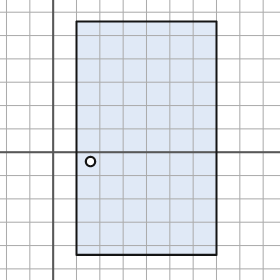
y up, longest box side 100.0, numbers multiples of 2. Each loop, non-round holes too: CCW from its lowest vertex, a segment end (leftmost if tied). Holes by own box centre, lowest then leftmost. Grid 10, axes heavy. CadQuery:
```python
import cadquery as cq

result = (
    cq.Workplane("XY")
    .moveTo(10.0, -44.0)
    .lineTo(70.0, -44.0)
    .lineTo(70.0, 56.0)
    .lineTo(10.0, 56.0)
    .close()
    .moveTo(16.0, -4.0)
    .circle(2.0)
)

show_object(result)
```